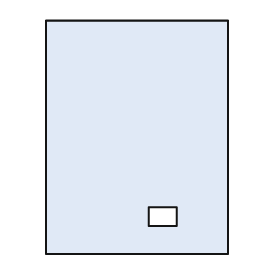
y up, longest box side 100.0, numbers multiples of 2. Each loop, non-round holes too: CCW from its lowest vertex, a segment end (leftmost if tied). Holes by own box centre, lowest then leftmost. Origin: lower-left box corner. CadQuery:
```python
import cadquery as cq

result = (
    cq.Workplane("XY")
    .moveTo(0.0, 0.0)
    .lineTo(78.0, 0.0)
    .lineTo(78.0, 100.0)
    .lineTo(0.0, 100.0)
    .close()
    .moveTo(44.0, 12.0)
    .lineTo(56.0, 12.0)
    .lineTo(56.0, 20.0)
    .lineTo(44.0, 20.0)
    .close()
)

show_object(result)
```